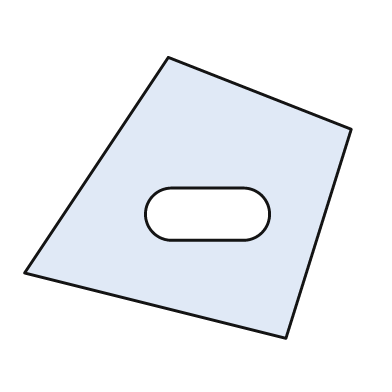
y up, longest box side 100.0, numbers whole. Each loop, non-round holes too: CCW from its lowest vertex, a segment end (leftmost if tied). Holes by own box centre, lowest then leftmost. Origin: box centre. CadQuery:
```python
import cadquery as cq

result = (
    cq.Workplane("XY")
    .moveTo(30.0, -43.0)
    .lineTo(50.0, 21.0)
    .lineTo(-6.0, 43.0)
    .lineTo(-50.0, -23.0)
    .close()
    .moveTo(-5.0, -13.0)
    .lineTo(17.0, -13.0)
    .threePointArc((25.0, -5.0), (17.0, 3.0))
    .lineTo(-5.0, 3.0)
    .threePointArc((-13.0, -5.0), (-5.0, -13.0))
    .close()
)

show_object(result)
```